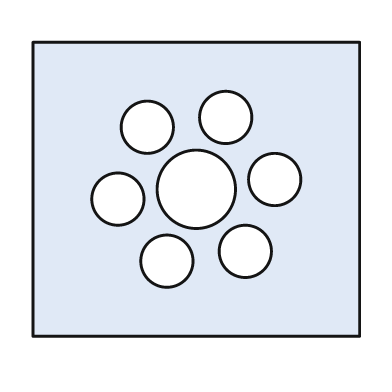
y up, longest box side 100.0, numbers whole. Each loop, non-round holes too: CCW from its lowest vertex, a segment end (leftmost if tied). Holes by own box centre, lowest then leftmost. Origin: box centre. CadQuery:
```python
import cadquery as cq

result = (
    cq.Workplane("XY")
    .moveTo(-50.0, -45.0)
    .lineTo(50.0, -45.0)
    .lineTo(50.0, 45.0)
    .lineTo(-50.0, 45.0)
    .close()
    .moveTo(-9.0, -22.0)
    .circle(8.0)
    .moveTo(15.0, -19.0)
    .circle(8.0)
    .moveTo(-24.0, -3.0)
    .circle(8.0)
    .moveTo(0.0, 0.0)
    .circle(12.0)
    .moveTo(24.0, 3.0)
    .circle(8.0)
    .moveTo(-15.0, 19.0)
    .circle(8.0)
    .moveTo(9.0, 22.0)
    .circle(8.0)
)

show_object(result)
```